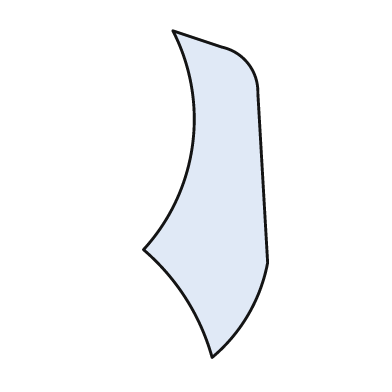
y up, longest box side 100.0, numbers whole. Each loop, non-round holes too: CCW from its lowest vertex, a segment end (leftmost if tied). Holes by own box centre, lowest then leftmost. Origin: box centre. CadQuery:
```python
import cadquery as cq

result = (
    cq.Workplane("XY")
    .moveTo(2.0, -50.0)
    .threePointArc((13.0, -37.0), (19.0, -21.0))
    .lineTo(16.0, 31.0)
    .threePointArc((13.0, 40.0), (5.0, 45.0))
    .lineTo(-10.0, 50.0)
    .threePointArc((-4.0, 15.0), (-19.0, -17.0))
    .threePointArc((-6.0, -32.0), (2.0, -50.0))
    .close()
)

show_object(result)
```